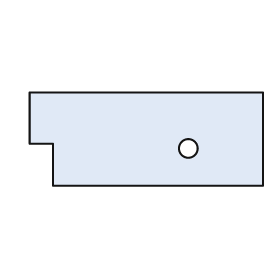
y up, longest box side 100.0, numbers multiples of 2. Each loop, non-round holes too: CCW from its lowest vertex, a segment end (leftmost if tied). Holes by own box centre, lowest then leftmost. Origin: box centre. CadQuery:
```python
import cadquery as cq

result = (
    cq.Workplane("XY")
    .moveTo(-40.0, -20.0)
    .lineTo(50.0, -20.0)
    .lineTo(50.0, 20.0)
    .lineTo(-50.0, 20.0)
    .lineTo(-50.0, -2.0)
    .lineTo(-40.0, -2.0)
    .close()
    .moveTo(18.0, -4.0)
    .circle(4.0)
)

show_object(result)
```